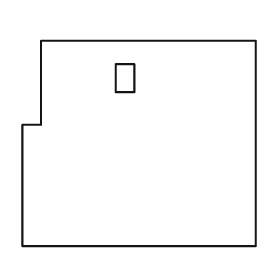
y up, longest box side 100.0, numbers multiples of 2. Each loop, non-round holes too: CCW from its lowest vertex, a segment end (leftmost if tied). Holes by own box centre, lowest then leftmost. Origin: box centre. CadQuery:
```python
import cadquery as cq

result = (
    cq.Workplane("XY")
    .moveTo(-50.0, -44.0)
    .lineTo(50.0, -44.0)
    .lineTo(50.0, 44.0)
    .lineTo(-42.0, 44.0)
    .lineTo(-42.0, 8.0)
    .lineTo(-50.0, 8.0)
    .close()
    .moveTo(-10.0, 22.0)
    .lineTo(-2.0, 22.0)
    .lineTo(-2.0, 34.0)
    .lineTo(-10.0, 34.0)
    .close()
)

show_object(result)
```